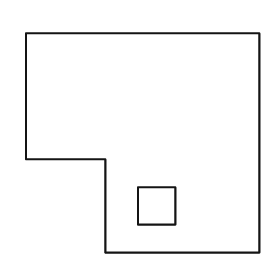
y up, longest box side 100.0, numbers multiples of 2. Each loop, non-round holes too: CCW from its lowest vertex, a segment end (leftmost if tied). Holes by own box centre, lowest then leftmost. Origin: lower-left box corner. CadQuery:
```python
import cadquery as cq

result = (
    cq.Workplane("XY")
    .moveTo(34.0, 0.0)
    .lineTo(100.0, 0.0)
    .lineTo(100.0, 94.0)
    .lineTo(0.0, 94.0)
    .lineTo(0.0, 40.0)
    .lineTo(34.0, 40.0)
    .close()
    .moveTo(48.0, 12.0)
    .lineTo(64.0, 12.0)
    .lineTo(64.0, 28.0)
    .lineTo(48.0, 28.0)
    .close()
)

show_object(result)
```